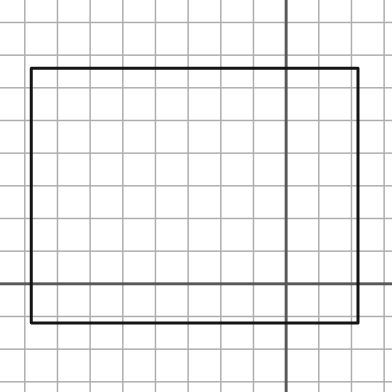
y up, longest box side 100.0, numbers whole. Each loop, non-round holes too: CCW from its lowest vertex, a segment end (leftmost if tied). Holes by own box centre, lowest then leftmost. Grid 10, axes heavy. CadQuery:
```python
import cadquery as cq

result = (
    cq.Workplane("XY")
    .moveTo(-78.0, -12.0)
    .lineTo(22.0, -12.0)
    .lineTo(22.0, 66.0)
    .lineTo(-78.0, 66.0)
    .close()
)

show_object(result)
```